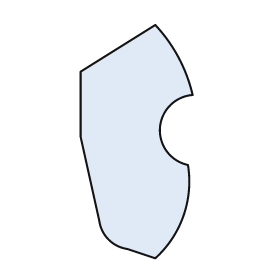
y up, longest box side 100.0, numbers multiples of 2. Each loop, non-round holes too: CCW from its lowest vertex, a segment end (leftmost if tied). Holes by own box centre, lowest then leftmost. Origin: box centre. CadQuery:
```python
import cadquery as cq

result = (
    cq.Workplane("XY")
    .moveTo(8.0, -50.0)
    .threePointArc((20.0, -32.0), (22.0, -10.0))
    .threePointArc((10.0, 6.0), (24.0, 20.0))
    .threePointArc((18.0, 36.0), (8.0, 50.0))
    .lineTo(-24.0, 30.0)
    .lineTo(-24.0, 2.0)
    .lineTo(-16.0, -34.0)
    .threePointArc((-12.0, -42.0), (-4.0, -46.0))
    .close()
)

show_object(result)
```